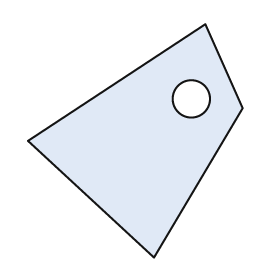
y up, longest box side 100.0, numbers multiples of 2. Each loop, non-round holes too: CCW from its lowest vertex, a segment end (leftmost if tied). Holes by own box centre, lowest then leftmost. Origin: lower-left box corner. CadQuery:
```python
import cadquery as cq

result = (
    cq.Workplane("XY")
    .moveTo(54.0, 0.0)
    .lineTo(92.0, 64.0)
    .lineTo(76.0, 100.0)
    .lineTo(0.0, 50.0)
    .close()
    .moveTo(70.0, 68.0)
    .circle(8.0)
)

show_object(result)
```